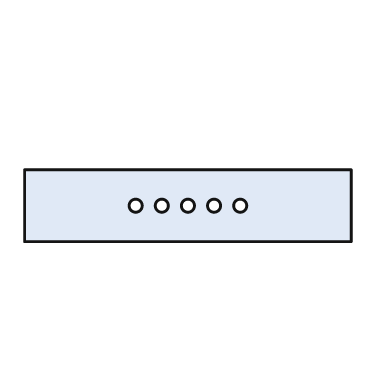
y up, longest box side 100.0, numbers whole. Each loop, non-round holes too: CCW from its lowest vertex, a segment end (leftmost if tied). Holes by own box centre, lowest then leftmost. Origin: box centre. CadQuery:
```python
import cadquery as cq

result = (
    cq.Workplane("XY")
    .moveTo(-50.0, -11.0)
    .lineTo(50.0, -11.0)
    .lineTo(50.0, 11.0)
    .lineTo(-50.0, 11.0)
    .close()
    .moveTo(-16.0, 0.0)
    .circle(2.0)
    .moveTo(-8.0, 0.0)
    .circle(2.0)
    .moveTo(0.0, 0.0)
    .circle(2.0)
    .moveTo(8.0, 0.0)
    .circle(2.0)
    .moveTo(16.0, 0.0)
    .circle(2.0)
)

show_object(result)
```